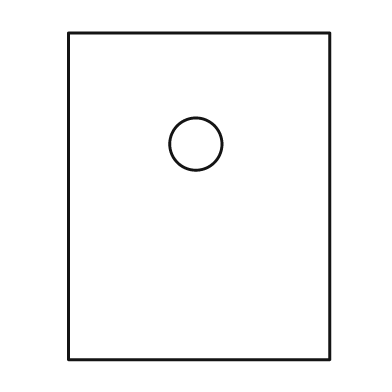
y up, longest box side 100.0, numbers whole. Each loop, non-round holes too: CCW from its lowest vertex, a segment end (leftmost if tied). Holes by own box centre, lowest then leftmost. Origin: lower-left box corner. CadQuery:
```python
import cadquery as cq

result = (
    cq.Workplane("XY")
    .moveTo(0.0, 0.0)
    .lineTo(80.0, 0.0)
    .lineTo(80.0, 100.0)
    .lineTo(0.0, 100.0)
    .close()
    .moveTo(39.0, 66.0)
    .circle(8.0)
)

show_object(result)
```